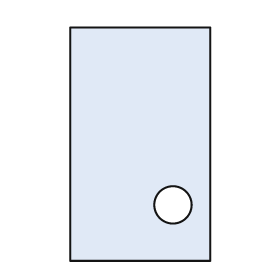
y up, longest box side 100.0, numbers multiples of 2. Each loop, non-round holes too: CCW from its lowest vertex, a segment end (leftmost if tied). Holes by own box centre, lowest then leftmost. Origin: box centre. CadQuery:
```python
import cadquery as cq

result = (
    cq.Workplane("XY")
    .moveTo(-30.0, -50.0)
    .lineTo(30.0, -50.0)
    .lineTo(30.0, 50.0)
    .lineTo(-30.0, 50.0)
    .close()
    .moveTo(14.0, -26.0)
    .circle(8.0)
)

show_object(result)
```